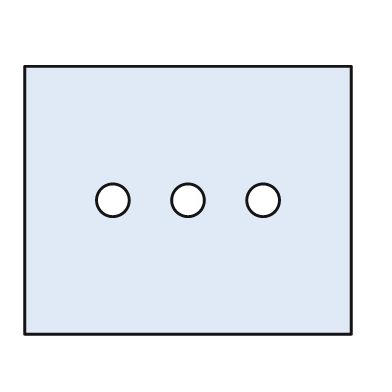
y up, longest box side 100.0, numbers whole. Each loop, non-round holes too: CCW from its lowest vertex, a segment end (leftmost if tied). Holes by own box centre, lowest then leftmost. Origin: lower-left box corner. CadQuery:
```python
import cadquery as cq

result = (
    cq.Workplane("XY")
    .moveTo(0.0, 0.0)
    .lineTo(100.0, 0.0)
    .lineTo(100.0, 82.0)
    .lineTo(0.0, 82.0)
    .close()
    .moveTo(27.0, 41.0)
    .circle(5.0)
    .moveTo(50.0, 41.0)
    .circle(5.0)
    .moveTo(73.0, 41.0)
    .circle(5.0)
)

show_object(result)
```